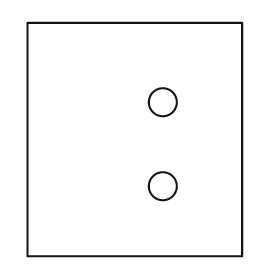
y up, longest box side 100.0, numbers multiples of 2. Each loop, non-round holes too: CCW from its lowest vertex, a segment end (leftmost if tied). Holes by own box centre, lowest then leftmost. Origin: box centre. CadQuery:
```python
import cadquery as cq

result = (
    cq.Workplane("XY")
    .moveTo(-46.0, -50.0)
    .lineTo(46.0, -50.0)
    .lineTo(46.0, 50.0)
    .lineTo(-46.0, 50.0)
    .close()
    .moveTo(12.0, -20.0)
    .circle(6.0)
    .moveTo(12.0, 16.0)
    .circle(6.0)
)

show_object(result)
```